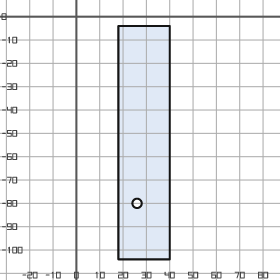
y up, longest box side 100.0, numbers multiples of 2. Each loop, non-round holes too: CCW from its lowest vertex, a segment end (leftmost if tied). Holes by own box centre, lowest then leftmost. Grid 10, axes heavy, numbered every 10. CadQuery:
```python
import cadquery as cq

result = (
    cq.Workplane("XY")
    .moveTo(18.0, -104.0)
    .lineTo(40.0, -104.0)
    .lineTo(40.0, -4.0)
    .lineTo(18.0, -4.0)
    .close()
    .moveTo(26.0, -80.0)
    .circle(2.0)
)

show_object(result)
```